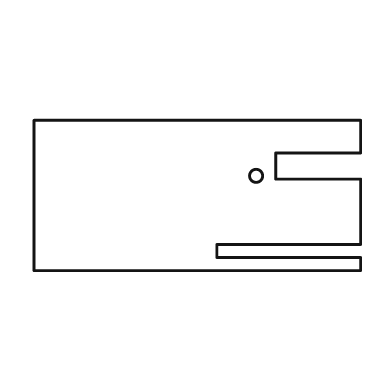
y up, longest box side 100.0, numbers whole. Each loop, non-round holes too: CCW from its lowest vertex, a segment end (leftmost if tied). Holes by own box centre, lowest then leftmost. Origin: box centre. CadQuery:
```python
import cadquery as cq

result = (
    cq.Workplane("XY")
    .moveTo(-50.0, -23.0)
    .lineTo(50.0, -23.0)
    .lineTo(50.0, -19.0)
    .lineTo(6.0, -19.0)
    .lineTo(6.0, -15.0)
    .lineTo(50.0, -15.0)
    .lineTo(50.0, 5.0)
    .lineTo(24.0, 5.0)
    .lineTo(24.0, 13.0)
    .lineTo(50.0, 13.0)
    .lineTo(50.0, 23.0)
    .lineTo(-50.0, 23.0)
    .close()
    .moveTo(18.0, 6.0)
    .circle(2.0)
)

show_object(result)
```